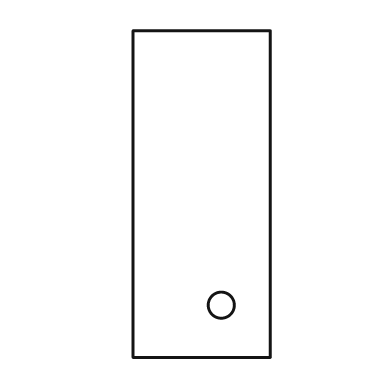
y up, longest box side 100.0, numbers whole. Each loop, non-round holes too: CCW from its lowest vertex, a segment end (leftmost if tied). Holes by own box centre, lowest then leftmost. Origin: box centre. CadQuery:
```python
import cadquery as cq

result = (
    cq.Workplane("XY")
    .moveTo(-21.0, -50.0)
    .lineTo(21.0, -50.0)
    .lineTo(21.0, 50.0)
    .lineTo(-21.0, 50.0)
    .close()
    .moveTo(6.0, -34.0)
    .circle(4.0)
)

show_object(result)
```